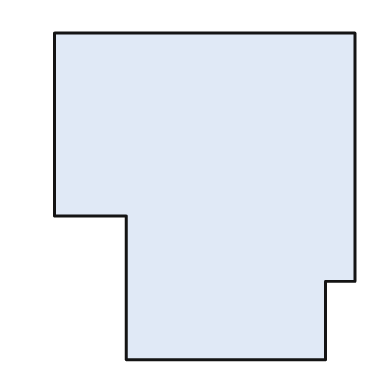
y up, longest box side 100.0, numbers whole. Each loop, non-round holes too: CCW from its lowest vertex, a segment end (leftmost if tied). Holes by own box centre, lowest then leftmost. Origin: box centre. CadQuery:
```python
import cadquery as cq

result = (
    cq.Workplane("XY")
    .moveTo(-24.0, -50.0)
    .lineTo(37.0, -50.0)
    .lineTo(37.0, -26.0)
    .lineTo(46.0, -26.0)
    .lineTo(46.0, 50.0)
    .lineTo(-46.0, 50.0)
    .lineTo(-46.0, -6.0)
    .lineTo(-24.0, -6.0)
    .close()
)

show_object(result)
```